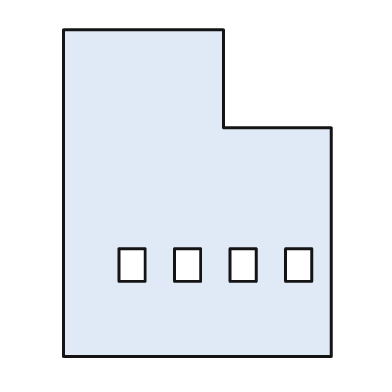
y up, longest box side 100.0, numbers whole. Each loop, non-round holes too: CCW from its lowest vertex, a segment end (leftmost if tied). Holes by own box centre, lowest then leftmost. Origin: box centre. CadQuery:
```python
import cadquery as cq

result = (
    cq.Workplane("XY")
    .moveTo(-41.0, -50.0)
    .lineTo(41.0, -50.0)
    .lineTo(41.0, 20.0)
    .lineTo(8.0, 20.0)
    .lineTo(8.0, 50.0)
    .lineTo(-41.0, 50.0)
    .close()
    .moveTo(-24.0, -27.0)
    .lineTo(-16.0, -27.0)
    .lineTo(-16.0, -17.0)
    .lineTo(-24.0, -17.0)
    .close()
    .moveTo(-7.0, -27.0)
    .lineTo(1.0, -27.0)
    .lineTo(1.0, -17.0)
    .lineTo(-7.0, -17.0)
    .close()
    .moveTo(10.0, -27.0)
    .lineTo(18.0, -27.0)
    .lineTo(18.0, -17.0)
    .lineTo(10.0, -17.0)
    .close()
    .moveTo(27.0, -27.0)
    .lineTo(35.0, -27.0)
    .lineTo(35.0, -17.0)
    .lineTo(27.0, -17.0)
    .close()
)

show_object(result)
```